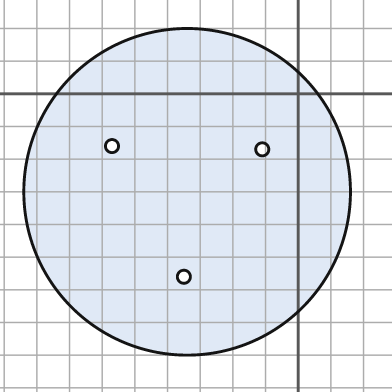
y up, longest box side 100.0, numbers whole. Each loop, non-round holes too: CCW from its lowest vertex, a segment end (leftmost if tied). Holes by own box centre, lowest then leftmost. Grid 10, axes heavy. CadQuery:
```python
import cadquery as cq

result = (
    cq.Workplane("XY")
    .moveTo(-34.0, -30.0)
    .circle(50.0)
    .moveTo(-35.0, -56.0)
    .circle(2.0)
    .moveTo(-11.0, -17.0)
    .circle(2.0)
    .moveTo(-57.0, -16.0)
    .circle(2.0)
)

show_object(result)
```